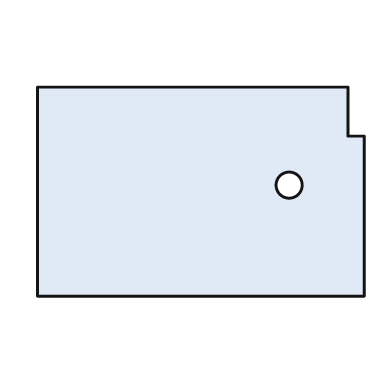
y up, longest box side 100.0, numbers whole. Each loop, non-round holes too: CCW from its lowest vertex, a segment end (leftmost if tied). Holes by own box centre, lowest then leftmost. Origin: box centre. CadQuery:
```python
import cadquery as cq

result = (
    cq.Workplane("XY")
    .moveTo(-50.0, -32.0)
    .lineTo(50.0, -32.0)
    .lineTo(50.0, 17.0)
    .lineTo(45.0, 17.0)
    .lineTo(45.0, 32.0)
    .lineTo(-50.0, 32.0)
    .close()
    .moveTo(27.0, 2.0)
    .circle(4.0)
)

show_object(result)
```